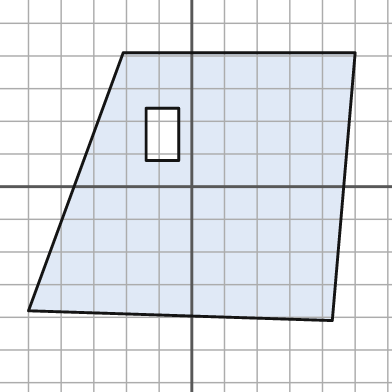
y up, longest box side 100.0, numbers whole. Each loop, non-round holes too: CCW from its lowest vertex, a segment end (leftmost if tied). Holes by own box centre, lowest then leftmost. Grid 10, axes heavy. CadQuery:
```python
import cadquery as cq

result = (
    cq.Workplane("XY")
    .moveTo(43.0, -41.0)
    .lineTo(50.0, 41.0)
    .lineTo(-21.0, 41.0)
    .lineTo(-50.0, -38.0)
    .close()
    .moveTo(-14.0, 8.0)
    .lineTo(-4.0, 8.0)
    .lineTo(-4.0, 24.0)
    .lineTo(-14.0, 24.0)
    .close()
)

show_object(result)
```